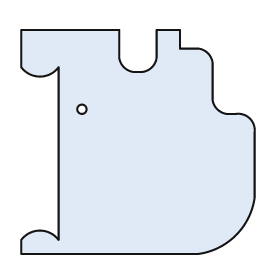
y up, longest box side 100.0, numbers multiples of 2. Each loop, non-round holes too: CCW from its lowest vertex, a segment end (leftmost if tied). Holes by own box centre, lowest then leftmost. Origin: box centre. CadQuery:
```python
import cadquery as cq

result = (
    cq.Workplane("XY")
    .moveTo(-50.0, -48.0)
    .lineTo(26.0, -48.0)
    .threePointArc((42.0, -40.0), (50.0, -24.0))
    .lineTo(50.0, 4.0)
    .threePointArc((48.0, 10.0), (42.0, 12.0))
    .lineTo(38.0, 12.0)
    .threePointArc((34.0, 14.0), (32.0, 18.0))
    .lineTo(32.0, 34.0)
    .threePointArc((30.0, 38.0), (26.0, 40.0))
    .lineTo(18.0, 40.0)
    .lineTo(18.0, 48.0)
    .lineTo(8.0, 48.0)
    .lineTo(8.0, 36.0)
    .threePointArc((6.0, 32.0), (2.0, 30.0))
    .lineTo(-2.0, 30.0)
    .threePointArc((-6.0, 32.0), (-8.0, 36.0))
    .lineTo(-8.0, 48.0)
    .lineTo(-50.0, 48.0)
    .lineTo(-50.0, 32.0)
    .threePointArc((-42.0, 28.0), (-34.0, 32.0))
    .lineTo(-34.0, -42.0)
    .threePointArc((-42.0, -38.0), (-50.0, -42.0))
    .close()
    .moveTo(-24.0, 14.0)
    .circle(2.0)
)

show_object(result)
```